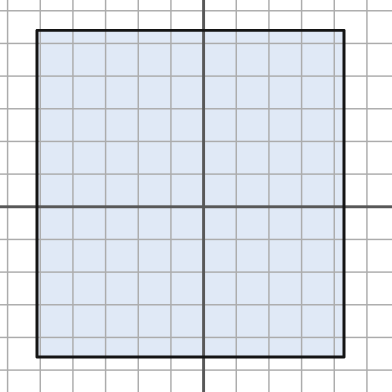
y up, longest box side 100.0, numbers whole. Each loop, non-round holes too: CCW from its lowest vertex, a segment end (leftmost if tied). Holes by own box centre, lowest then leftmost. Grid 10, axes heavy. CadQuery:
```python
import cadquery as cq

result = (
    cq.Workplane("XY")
    .moveTo(-51.0, -46.0)
    .lineTo(43.0, -46.0)
    .lineTo(43.0, 54.0)
    .lineTo(-51.0, 54.0)
    .close()
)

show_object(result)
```